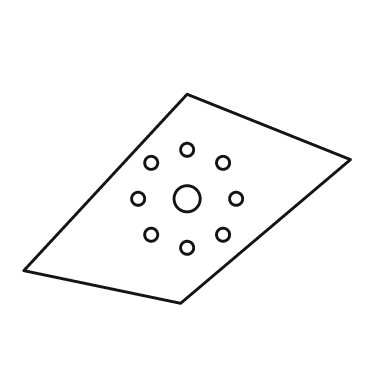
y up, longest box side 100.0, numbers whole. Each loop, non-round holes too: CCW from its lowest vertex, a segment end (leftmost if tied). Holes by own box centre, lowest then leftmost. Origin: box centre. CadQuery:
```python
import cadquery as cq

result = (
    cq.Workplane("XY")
    .moveTo(-2.0, -32.0)
    .lineTo(50.0, 12.0)
    .lineTo(0.0, 32.0)
    .lineTo(-50.0, -22.0)
    .close()
    .moveTo(0.0, -15.0)
    .circle(2.0)
    .moveTo(-11.0, -11.0)
    .circle(2.0)
    .moveTo(11.0, -11.0)
    .circle(2.0)
    .moveTo(-15.0, 0.0)
    .circle(2.0)
    .moveTo(0.0, 0.0)
    .circle(4.0)
    .moveTo(15.0, 0.0)
    .circle(2.0)
    .moveTo(-11.0, 11.0)
    .circle(2.0)
    .moveTo(11.0, 11.0)
    .circle(2.0)
    .moveTo(0.0, 15.0)
    .circle(2.0)
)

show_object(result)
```